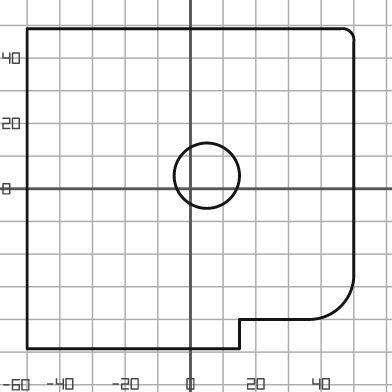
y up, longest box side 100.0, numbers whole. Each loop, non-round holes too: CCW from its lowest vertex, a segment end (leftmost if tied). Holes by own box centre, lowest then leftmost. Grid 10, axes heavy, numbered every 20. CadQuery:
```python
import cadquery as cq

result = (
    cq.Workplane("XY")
    .moveTo(-50.0, -49.0)
    .lineTo(15.0, -49.0)
    .lineTo(15.0, -40.0)
    .lineTo(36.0, -40.0)
    .threePointArc((46.0, -36.0), (50.0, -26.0))
    .lineTo(50.0, 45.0)
    .threePointArc((49.0, 48.0), (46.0, 49.0))
    .lineTo(-50.0, 49.0)
    .close()
    .moveTo(5.0, 4.0)
    .circle(10.0)
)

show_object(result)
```